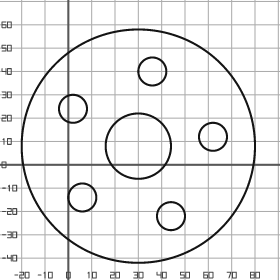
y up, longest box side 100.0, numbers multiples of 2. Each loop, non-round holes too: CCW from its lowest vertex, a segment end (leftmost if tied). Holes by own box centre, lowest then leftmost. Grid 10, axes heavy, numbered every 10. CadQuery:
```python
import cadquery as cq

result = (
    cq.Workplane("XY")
    .moveTo(30.0, 8.0)
    .circle(50.0)
    .moveTo(44.0, -22.0)
    .circle(6.0)
    .moveTo(6.0, -14.0)
    .circle(6.0)
    .moveTo(30.0, 8.0)
    .circle(14.0)
    .moveTo(62.0, 12.0)
    .circle(6.0)
    .moveTo(2.0, 24.0)
    .circle(6.0)
    .moveTo(36.0, 40.0)
    .circle(6.0)
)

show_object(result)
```